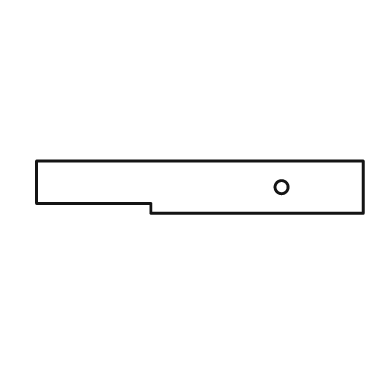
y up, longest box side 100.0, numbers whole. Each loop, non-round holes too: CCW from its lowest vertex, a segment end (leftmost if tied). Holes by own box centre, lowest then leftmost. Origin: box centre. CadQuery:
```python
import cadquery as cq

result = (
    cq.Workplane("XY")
    .moveTo(-15.0, -8.0)
    .lineTo(50.0, -8.0)
    .lineTo(50.0, 8.0)
    .lineTo(-50.0, 8.0)
    .lineTo(-50.0, -5.0)
    .lineTo(-15.0, -5.0)
    .close()
    .moveTo(25.0, 0.0)
    .circle(2.0)
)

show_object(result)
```